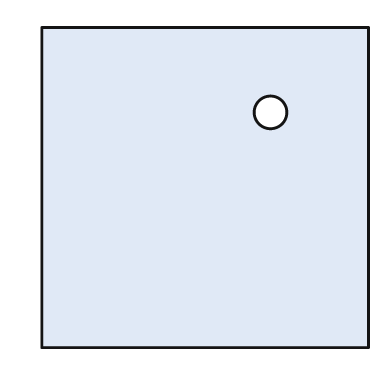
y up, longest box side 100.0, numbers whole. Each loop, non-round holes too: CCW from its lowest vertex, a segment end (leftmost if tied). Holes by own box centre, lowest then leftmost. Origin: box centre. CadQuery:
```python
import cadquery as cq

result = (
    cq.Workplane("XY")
    .moveTo(-50.0, -49.0)
    .lineTo(50.0, -49.0)
    .lineTo(50.0, 49.0)
    .lineTo(-50.0, 49.0)
    .close()
    .moveTo(20.0, 23.0)
    .circle(5.0)
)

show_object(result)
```